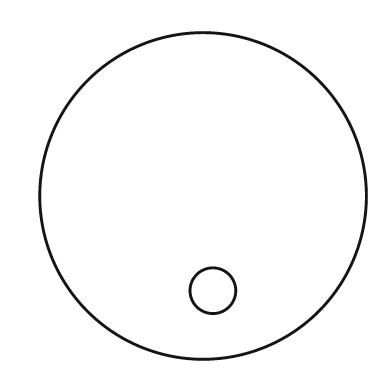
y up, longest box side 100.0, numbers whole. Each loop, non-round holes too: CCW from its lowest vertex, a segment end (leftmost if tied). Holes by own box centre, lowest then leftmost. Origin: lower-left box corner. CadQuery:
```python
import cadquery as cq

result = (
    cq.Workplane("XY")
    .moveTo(50.0, 50.0)
    .circle(50.0)
    .moveTo(53.0, 21.0)
    .circle(7.0)
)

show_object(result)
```